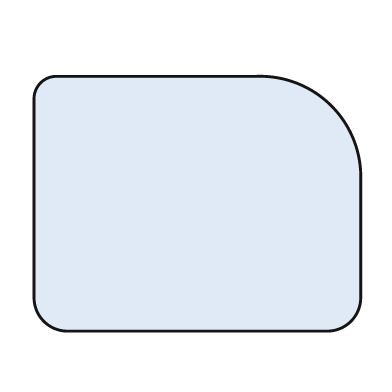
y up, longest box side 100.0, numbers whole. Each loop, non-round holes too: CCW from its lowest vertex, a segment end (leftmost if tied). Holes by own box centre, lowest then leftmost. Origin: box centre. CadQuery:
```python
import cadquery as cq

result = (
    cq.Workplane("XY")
    .moveTo(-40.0, -39.0)
    .lineTo(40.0, -39.0)
    .threePointArc((47.0, -36.0), (50.0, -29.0))
    .lineTo(50.0, 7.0)
    .threePointArc((41.0, 30.0), (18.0, 39.0))
    .lineTo(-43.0, 39.0)
    .threePointArc((-48.0, 37.0), (-50.0, 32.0))
    .lineTo(-50.0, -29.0)
    .threePointArc((-47.0, -36.0), (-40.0, -39.0))
    .close()
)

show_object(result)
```